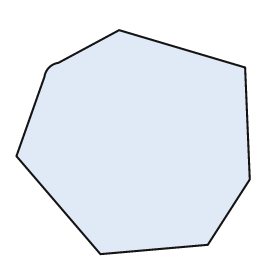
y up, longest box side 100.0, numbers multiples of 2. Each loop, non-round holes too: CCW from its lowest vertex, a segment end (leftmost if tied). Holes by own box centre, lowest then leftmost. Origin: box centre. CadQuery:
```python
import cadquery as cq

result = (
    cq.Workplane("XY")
    .moveTo(-14.0, -48.0)
    .lineTo(32.0, -44.0)
    .lineTo(50.0, -16.0)
    .lineTo(48.0, 32.0)
    .lineTo(-6.0, 48.0)
    .lineTo(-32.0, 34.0)
    .threePointArc((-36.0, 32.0), (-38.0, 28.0))
    .lineTo(-50.0, -6.0)
    .close()
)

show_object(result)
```